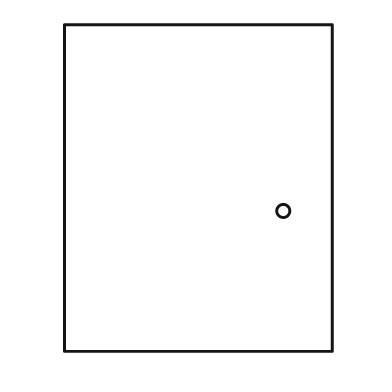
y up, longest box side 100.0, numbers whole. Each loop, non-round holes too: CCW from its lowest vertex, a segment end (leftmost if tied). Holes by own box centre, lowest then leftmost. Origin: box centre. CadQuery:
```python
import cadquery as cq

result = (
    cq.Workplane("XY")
    .moveTo(-41.0, -50.0)
    .lineTo(41.0, -50.0)
    .lineTo(41.0, 50.0)
    .lineTo(-41.0, 50.0)
    .close()
    .moveTo(26.0, -7.0)
    .circle(2.0)
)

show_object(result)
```